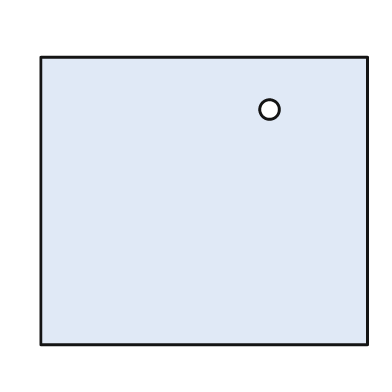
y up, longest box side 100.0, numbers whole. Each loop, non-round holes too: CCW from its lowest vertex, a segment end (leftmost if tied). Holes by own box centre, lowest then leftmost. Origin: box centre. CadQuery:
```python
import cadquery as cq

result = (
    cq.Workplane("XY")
    .moveTo(-50.0, -44.0)
    .lineTo(50.0, -44.0)
    .lineTo(50.0, 44.0)
    .lineTo(-50.0, 44.0)
    .close()
    .moveTo(20.0, 28.0)
    .circle(3.0)
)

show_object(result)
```